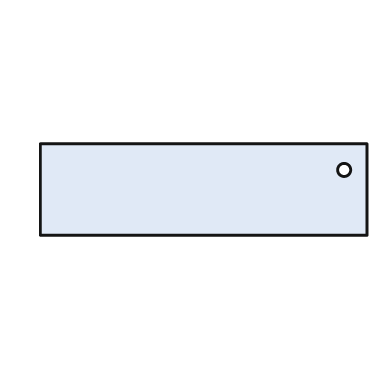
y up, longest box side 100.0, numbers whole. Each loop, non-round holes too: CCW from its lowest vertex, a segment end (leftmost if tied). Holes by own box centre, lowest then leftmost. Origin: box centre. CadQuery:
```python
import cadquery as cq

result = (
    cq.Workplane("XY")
    .moveTo(-50.0, -14.0)
    .lineTo(50.0, -14.0)
    .lineTo(50.0, 14.0)
    .lineTo(-50.0, 14.0)
    .close()
    .moveTo(43.0, 6.0)
    .circle(2.0)
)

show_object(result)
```